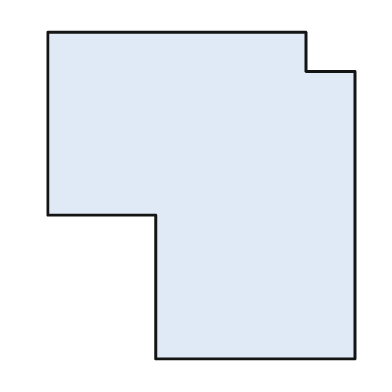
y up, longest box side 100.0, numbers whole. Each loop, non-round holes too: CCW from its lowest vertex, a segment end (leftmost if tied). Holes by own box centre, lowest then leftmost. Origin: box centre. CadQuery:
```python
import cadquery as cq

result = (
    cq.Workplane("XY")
    .moveTo(-14.0, -50.0)
    .lineTo(47.0, -50.0)
    .lineTo(47.0, 38.0)
    .lineTo(32.0, 38.0)
    .lineTo(32.0, 50.0)
    .lineTo(-47.0, 50.0)
    .lineTo(-47.0, -6.0)
    .lineTo(-14.0, -6.0)
    .close()
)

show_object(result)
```